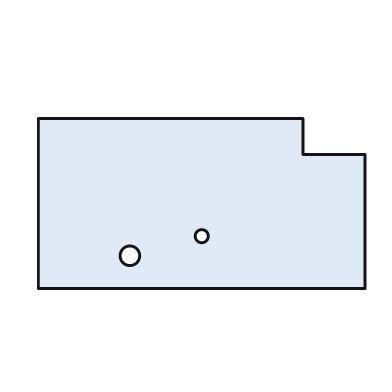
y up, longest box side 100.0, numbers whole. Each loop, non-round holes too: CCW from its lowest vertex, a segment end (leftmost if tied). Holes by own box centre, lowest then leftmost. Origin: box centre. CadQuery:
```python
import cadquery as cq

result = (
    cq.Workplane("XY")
    .moveTo(-50.0, -26.0)
    .lineTo(50.0, -26.0)
    .lineTo(50.0, 15.0)
    .lineTo(31.0, 15.0)
    .lineTo(31.0, 26.0)
    .lineTo(-50.0, 26.0)
    .close()
    .moveTo(-22.0, -16.0)
    .circle(3.0)
    .moveTo(0.0, -10.0)
    .circle(2.0)
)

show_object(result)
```